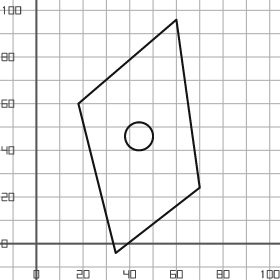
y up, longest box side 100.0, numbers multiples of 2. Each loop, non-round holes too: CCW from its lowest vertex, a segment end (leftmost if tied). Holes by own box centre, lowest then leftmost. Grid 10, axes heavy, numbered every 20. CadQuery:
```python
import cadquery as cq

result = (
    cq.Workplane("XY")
    .moveTo(34.0, -4.0)
    .lineTo(70.0, 24.0)
    .lineTo(60.0, 96.0)
    .lineTo(18.0, 60.0)
    .close()
    .moveTo(44.0, 46.0)
    .circle(6.0)
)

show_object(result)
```